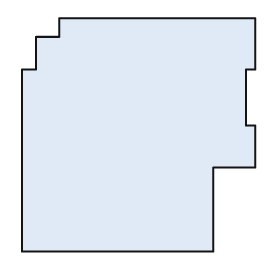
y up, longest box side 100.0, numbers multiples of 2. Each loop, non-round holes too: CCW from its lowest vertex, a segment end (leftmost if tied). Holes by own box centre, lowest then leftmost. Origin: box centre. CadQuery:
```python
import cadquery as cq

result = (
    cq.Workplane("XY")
    .moveTo(-50.0, -50.0)
    .lineTo(32.0, -50.0)
    .lineTo(32.0, -14.0)
    .lineTo(50.0, -14.0)
    .lineTo(50.0, 4.0)
    .lineTo(46.0, 4.0)
    .lineTo(46.0, 28.0)
    .lineTo(50.0, 28.0)
    .lineTo(50.0, 50.0)
    .lineTo(-34.0, 50.0)
    .lineTo(-34.0, 42.0)
    .lineTo(-44.0, 42.0)
    .lineTo(-44.0, 28.0)
    .lineTo(-50.0, 28.0)
    .close()
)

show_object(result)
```